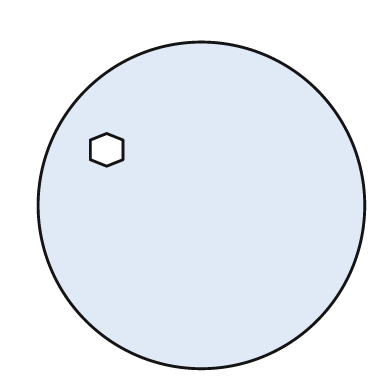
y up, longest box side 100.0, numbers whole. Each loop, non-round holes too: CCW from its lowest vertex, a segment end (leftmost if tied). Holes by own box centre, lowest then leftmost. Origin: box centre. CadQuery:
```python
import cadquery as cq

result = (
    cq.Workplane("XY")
    .moveTo(0.0, 0.0)
    .circle(50.0)
    .moveTo(-29.0, 12.0)
    .lineTo(-24.0, 14.0)
    .lineTo(-24.0, 20.0)
    .lineTo(-29.0, 22.0)
    .lineTo(-34.0, 20.0)
    .lineTo(-34.0, 14.0)
    .close()
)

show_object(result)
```